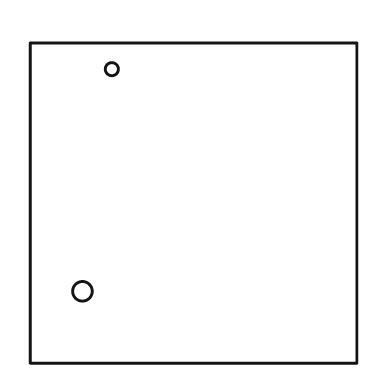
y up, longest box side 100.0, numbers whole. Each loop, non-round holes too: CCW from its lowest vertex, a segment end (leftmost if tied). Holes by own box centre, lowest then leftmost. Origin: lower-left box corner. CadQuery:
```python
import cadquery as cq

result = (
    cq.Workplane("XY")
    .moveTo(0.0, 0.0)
    .lineTo(100.0, 0.0)
    .lineTo(100.0, 98.0)
    .lineTo(0.0, 98.0)
    .close()
    .moveTo(16.0, 22.0)
    .circle(3.0)
    .moveTo(25.0, 90.0)
    .circle(2.0)
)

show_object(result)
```